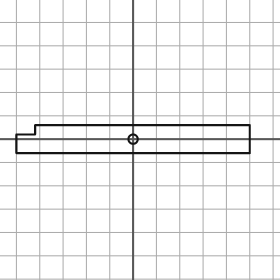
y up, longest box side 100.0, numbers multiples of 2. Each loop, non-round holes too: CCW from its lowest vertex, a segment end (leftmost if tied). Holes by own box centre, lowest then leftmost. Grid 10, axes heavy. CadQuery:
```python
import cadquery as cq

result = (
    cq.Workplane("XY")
    .moveTo(-50.0, -6.0)
    .lineTo(50.0, -6.0)
    .lineTo(50.0, 6.0)
    .lineTo(-42.0, 6.0)
    .lineTo(-42.0, 2.0)
    .lineTo(-50.0, 2.0)
    .close()
    .moveTo(0.0, 0.0)
    .circle(2.0)
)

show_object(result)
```